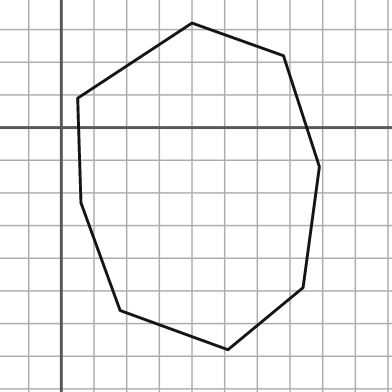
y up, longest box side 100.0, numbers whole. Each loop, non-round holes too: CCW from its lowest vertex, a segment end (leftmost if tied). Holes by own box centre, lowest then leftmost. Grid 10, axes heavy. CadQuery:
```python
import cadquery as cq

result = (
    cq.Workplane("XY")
    .moveTo(51.0, -68.0)
    .lineTo(74.0, -49.0)
    .lineTo(79.0, -12.0)
    .lineTo(68.0, 22.0)
    .lineTo(40.0, 32.0)
    .lineTo(5.0, 9.0)
    .lineTo(6.0, -23.0)
    .lineTo(18.0, -56.0)
    .close()
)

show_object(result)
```